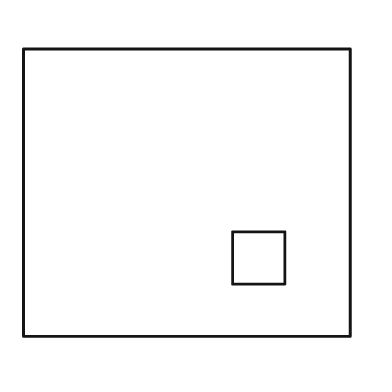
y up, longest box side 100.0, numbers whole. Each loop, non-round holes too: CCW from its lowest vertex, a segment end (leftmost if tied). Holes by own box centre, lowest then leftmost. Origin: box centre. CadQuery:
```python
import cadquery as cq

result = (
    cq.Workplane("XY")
    .moveTo(-50.0, -44.0)
    .lineTo(50.0, -44.0)
    .lineTo(50.0, 44.0)
    .lineTo(-50.0, 44.0)
    .close()
    .moveTo(14.0, -28.0)
    .lineTo(30.0, -28.0)
    .lineTo(30.0, -12.0)
    .lineTo(14.0, -12.0)
    .close()
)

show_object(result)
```